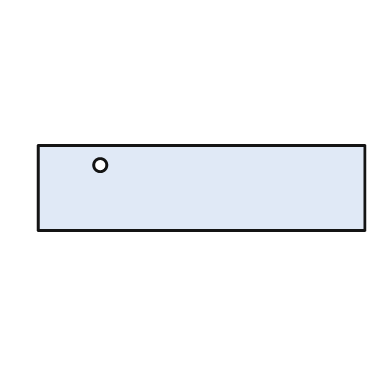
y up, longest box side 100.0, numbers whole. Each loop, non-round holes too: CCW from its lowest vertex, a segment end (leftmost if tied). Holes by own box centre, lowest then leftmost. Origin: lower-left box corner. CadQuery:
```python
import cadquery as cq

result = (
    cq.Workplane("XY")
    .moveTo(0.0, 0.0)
    .lineTo(100.0, 0.0)
    .lineTo(100.0, 26.0)
    .lineTo(0.0, 26.0)
    .close()
    .moveTo(19.0, 20.0)
    .circle(2.0)
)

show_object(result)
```